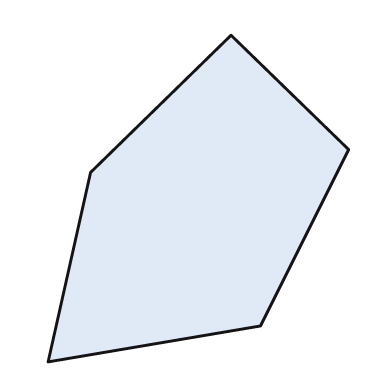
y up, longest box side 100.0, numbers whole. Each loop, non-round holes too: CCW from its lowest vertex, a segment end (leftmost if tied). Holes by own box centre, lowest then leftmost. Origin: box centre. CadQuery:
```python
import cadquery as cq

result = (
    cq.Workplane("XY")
    .moveTo(-46.0, -50.0)
    .lineTo(19.0, -39.0)
    .lineTo(46.0, 15.0)
    .lineTo(10.0, 50.0)
    .lineTo(-33.0, 8.0)
    .close()
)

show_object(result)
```